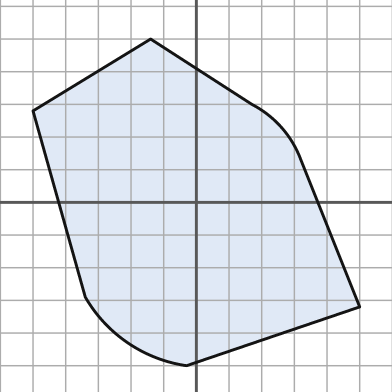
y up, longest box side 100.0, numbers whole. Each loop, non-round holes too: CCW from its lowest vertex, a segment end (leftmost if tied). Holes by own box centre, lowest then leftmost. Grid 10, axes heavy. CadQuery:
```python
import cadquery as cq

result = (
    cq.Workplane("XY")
    .moveTo(-3.0, -50.0)
    .lineTo(50.0, -32.0)
    .lineTo(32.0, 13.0)
    .threePointArc((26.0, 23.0), (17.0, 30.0))
    .lineTo(-14.0, 50.0)
    .lineTo(-50.0, 28.0)
    .lineTo(-34.0, -29.0)
    .threePointArc((-21.0, -43.0), (-3.0, -50.0))
    .close()
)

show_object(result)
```